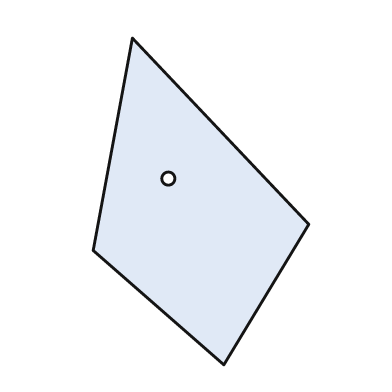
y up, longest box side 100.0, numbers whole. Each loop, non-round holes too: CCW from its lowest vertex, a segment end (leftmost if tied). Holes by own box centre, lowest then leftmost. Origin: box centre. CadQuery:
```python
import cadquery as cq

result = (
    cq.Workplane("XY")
    .moveTo(7.0, -50.0)
    .lineTo(33.0, -7.0)
    .lineTo(-21.0, 50.0)
    .lineTo(-33.0, -15.0)
    .close()
    .moveTo(-10.0, 7.0)
    .circle(2.0)
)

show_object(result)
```